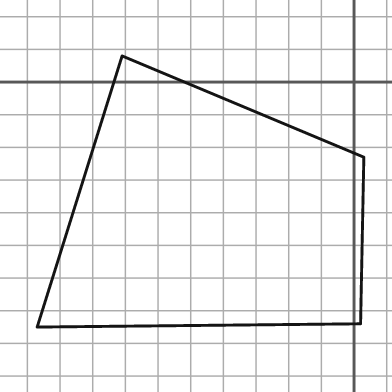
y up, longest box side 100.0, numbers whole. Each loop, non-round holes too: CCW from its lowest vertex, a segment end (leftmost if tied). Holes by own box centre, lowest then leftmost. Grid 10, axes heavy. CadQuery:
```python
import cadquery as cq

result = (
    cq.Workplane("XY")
    .moveTo(-97.0, -75.0)
    .lineTo(2.0, -74.0)
    .lineTo(3.0, -23.0)
    .lineTo(-71.0, 8.0)
    .close()
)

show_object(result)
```